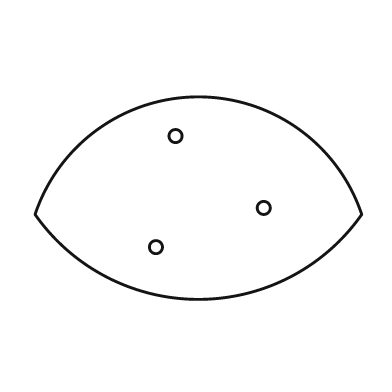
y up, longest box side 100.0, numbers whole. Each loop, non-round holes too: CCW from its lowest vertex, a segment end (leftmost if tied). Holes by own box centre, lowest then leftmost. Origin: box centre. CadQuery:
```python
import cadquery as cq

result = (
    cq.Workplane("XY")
    .moveTo(-50.0, -5.0)
    .threePointArc((0.0, -31.0), (50.0, -5.0))
    .threePointArc((0.0, 31.0), (-50.0, -5.0))
    .close()
    .moveTo(-13.0, -15.0)
    .circle(2.0)
    .moveTo(20.0, -3.0)
    .circle(2.0)
    .moveTo(-7.0, 19.0)
    .circle(2.0)
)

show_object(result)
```